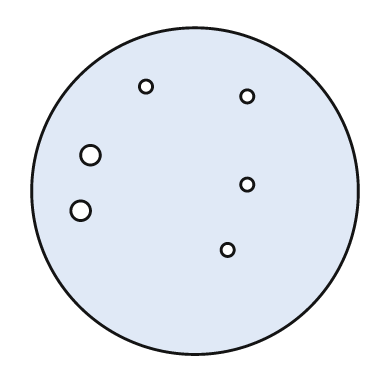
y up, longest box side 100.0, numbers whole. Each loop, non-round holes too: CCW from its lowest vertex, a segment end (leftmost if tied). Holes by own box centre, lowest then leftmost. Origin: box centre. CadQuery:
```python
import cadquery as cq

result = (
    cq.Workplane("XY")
    .moveTo(0.0, 0.0)
    .circle(50.0)
    .moveTo(10.0, -18.0)
    .circle(2.0)
    .moveTo(-35.0, -6.0)
    .circle(3.0)
    .moveTo(16.0, 2.0)
    .circle(2.0)
    .moveTo(-32.0, 11.0)
    .circle(3.0)
    .moveTo(16.0, 29.0)
    .circle(2.0)
    .moveTo(-15.0, 32.0)
    .circle(2.0)
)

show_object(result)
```